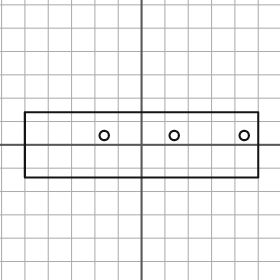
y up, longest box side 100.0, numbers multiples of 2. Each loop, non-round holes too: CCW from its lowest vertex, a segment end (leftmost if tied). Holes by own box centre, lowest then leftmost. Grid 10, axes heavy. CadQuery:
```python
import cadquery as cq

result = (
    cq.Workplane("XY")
    .moveTo(-50.0, -14.0)
    .lineTo(50.0, -14.0)
    .lineTo(50.0, 14.0)
    .lineTo(-50.0, 14.0)
    .close()
    .moveTo(-16.0, 4.0)
    .circle(2.0)
    .moveTo(14.0, 4.0)
    .circle(2.0)
    .moveTo(44.0, 4.0)
    .circle(2.0)
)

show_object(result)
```